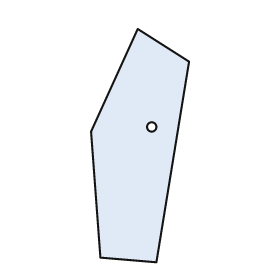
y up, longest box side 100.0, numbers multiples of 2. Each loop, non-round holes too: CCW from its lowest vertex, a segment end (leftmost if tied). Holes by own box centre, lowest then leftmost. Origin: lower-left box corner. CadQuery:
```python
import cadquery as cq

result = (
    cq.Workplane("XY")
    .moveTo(28.0, 0.0)
    .lineTo(42.0, 86.0)
    .lineTo(20.0, 100.0)
    .lineTo(0.0, 56.0)
    .lineTo(4.0, 2.0)
    .close()
    .moveTo(26.0, 58.0)
    .circle(2.0)
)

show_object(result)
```